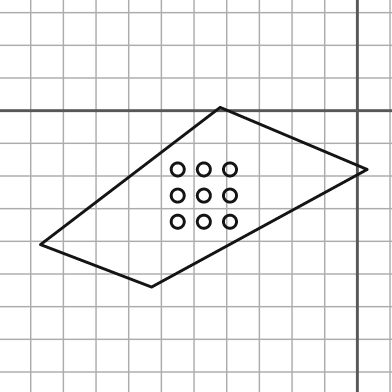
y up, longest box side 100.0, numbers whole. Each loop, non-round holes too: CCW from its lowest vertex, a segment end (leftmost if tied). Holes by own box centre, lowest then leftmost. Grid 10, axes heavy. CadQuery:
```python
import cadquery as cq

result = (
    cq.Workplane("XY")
    .moveTo(-63.0, -54.0)
    .lineTo(3.0, -18.0)
    .lineTo(-42.0, 1.0)
    .lineTo(-97.0, -41.0)
    .close()
    .moveTo(-55.0, -34.0)
    .circle(2.0)
    .moveTo(-47.0, -34.0)
    .circle(2.0)
    .moveTo(-39.0, -34.0)
    .circle(2.0)
    .moveTo(-55.0, -26.0)
    .circle(2.0)
    .moveTo(-47.0, -26.0)
    .circle(2.0)
    .moveTo(-39.0, -26.0)
    .circle(2.0)
    .moveTo(-55.0, -18.0)
    .circle(2.0)
    .moveTo(-47.0, -18.0)
    .circle(2.0)
    .moveTo(-39.0, -18.0)
    .circle(2.0)
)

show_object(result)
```